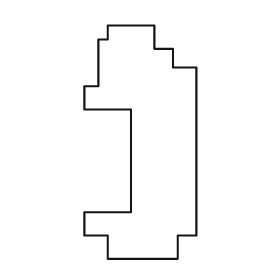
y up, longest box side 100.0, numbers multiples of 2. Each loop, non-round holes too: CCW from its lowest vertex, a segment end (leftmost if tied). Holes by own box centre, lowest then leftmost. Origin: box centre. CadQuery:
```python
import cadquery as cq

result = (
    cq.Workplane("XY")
    .moveTo(-14.0, -50.0)
    .lineTo(16.0, -50.0)
    .lineTo(16.0, -40.0)
    .lineTo(24.0, -40.0)
    .lineTo(24.0, 32.0)
    .lineTo(14.0, 32.0)
    .lineTo(14.0, 40.0)
    .lineTo(6.0, 40.0)
    .lineTo(6.0, 50.0)
    .lineTo(-14.0, 50.0)
    .lineTo(-14.0, 44.0)
    .lineTo(-18.0, 44.0)
    .lineTo(-18.0, 24.0)
    .lineTo(-24.0, 24.0)
    .lineTo(-24.0, 14.0)
    .lineTo(-4.0, 14.0)
    .lineTo(-4.0, -30.0)
    .lineTo(-24.0, -30.0)
    .lineTo(-24.0, -40.0)
    .lineTo(-14.0, -40.0)
    .close()
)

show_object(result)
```